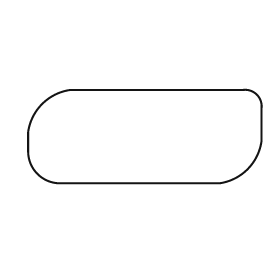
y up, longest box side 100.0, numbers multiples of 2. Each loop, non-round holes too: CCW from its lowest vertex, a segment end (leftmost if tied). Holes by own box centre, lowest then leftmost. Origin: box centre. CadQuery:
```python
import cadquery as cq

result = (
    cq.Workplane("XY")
    .moveTo(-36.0, -20.0)
    .lineTo(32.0, -20.0)
    .threePointArc((44.0, -14.0), (50.0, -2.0))
    .lineTo(50.0, 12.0)
    .threePointArc((48.0, 18.0), (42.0, 20.0))
    .lineTo(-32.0, 20.0)
    .threePointArc((-44.0, 14.0), (-50.0, 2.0))
    .lineTo(-50.0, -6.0)
    .threePointArc((-46.0, -16.0), (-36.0, -20.0))
    .close()
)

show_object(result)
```